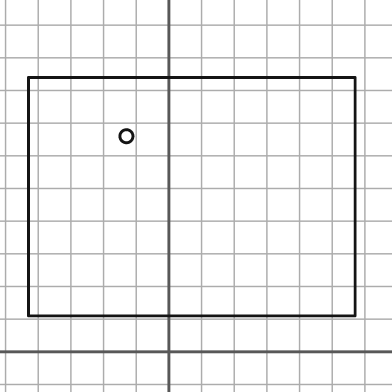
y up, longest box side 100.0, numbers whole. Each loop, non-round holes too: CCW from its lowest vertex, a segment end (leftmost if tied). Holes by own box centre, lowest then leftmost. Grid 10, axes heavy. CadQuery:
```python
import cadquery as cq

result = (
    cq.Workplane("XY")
    .moveTo(-43.0, 11.0)
    .lineTo(57.0, 11.0)
    .lineTo(57.0, 84.0)
    .lineTo(-43.0, 84.0)
    .close()
    .moveTo(-13.0, 66.0)
    .circle(2.0)
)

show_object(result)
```